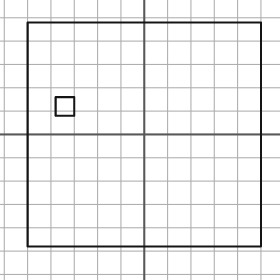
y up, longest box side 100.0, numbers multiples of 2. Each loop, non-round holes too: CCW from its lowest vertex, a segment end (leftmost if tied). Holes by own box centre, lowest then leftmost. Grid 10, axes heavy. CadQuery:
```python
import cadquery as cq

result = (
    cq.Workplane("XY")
    .moveTo(-50.0, -48.0)
    .lineTo(50.0, -48.0)
    .lineTo(50.0, 48.0)
    .lineTo(-50.0, 48.0)
    .close()
    .moveTo(-38.0, 8.0)
    .lineTo(-30.0, 8.0)
    .lineTo(-30.0, 16.0)
    .lineTo(-38.0, 16.0)
    .close()
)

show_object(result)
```